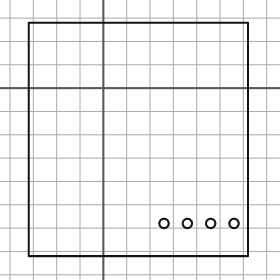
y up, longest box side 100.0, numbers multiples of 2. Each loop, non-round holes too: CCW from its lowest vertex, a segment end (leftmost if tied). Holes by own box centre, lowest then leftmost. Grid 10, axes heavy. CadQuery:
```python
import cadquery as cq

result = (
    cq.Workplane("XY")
    .moveTo(-32.0, -72.0)
    .lineTo(62.0, -72.0)
    .lineTo(62.0, 28.0)
    .lineTo(-32.0, 28.0)
    .close()
    .moveTo(26.0, -58.0)
    .circle(2.0)
    .moveTo(36.0, -58.0)
    .circle(2.0)
    .moveTo(46.0, -58.0)
    .circle(2.0)
    .moveTo(56.0, -58.0)
    .circle(2.0)
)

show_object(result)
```